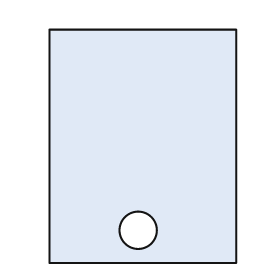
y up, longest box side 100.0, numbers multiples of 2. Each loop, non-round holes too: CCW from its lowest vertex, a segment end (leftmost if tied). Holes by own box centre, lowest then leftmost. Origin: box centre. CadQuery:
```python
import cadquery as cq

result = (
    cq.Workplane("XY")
    .moveTo(-40.0, -50.0)
    .lineTo(40.0, -50.0)
    .lineTo(40.0, 50.0)
    .lineTo(-40.0, 50.0)
    .close()
    .moveTo(-2.0, -36.0)
    .circle(8.0)
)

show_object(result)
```